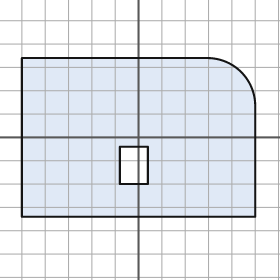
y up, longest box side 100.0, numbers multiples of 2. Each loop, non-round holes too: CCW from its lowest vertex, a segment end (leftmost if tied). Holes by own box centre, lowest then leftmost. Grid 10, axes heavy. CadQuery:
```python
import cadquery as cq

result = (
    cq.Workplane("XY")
    .moveTo(-50.0, -34.0)
    .lineTo(50.0, -34.0)
    .lineTo(50.0, 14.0)
    .threePointArc((44.0, 28.0), (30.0, 34.0))
    .lineTo(-50.0, 34.0)
    .close()
    .moveTo(-8.0, -20.0)
    .lineTo(4.0, -20.0)
    .lineTo(4.0, -4.0)
    .lineTo(-8.0, -4.0)
    .close()
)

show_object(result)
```